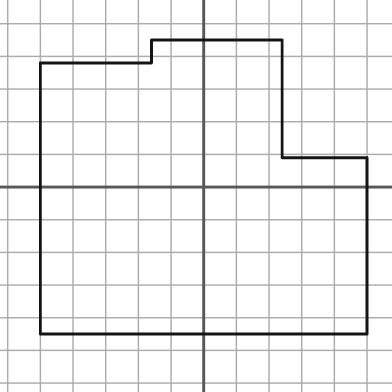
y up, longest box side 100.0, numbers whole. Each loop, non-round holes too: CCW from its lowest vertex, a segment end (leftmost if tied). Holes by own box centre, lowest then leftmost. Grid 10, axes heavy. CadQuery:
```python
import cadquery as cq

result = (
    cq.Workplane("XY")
    .moveTo(-50.0, -45.0)
    .lineTo(50.0, -45.0)
    .lineTo(50.0, 9.0)
    .lineTo(24.0, 9.0)
    .lineTo(24.0, 45.0)
    .lineTo(-16.0, 45.0)
    .lineTo(-16.0, 38.0)
    .lineTo(-50.0, 38.0)
    .close()
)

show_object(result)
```